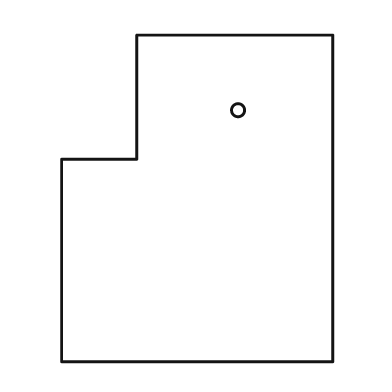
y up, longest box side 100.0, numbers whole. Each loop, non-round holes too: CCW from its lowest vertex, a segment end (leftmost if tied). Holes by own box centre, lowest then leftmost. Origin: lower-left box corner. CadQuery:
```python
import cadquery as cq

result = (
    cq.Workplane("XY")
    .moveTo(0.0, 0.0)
    .lineTo(83.0, 0.0)
    .lineTo(83.0, 100.0)
    .lineTo(23.0, 100.0)
    .lineTo(23.0, 62.0)
    .lineTo(0.0, 62.0)
    .close()
    .moveTo(54.0, 77.0)
    .circle(2.0)
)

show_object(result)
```